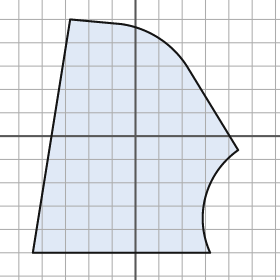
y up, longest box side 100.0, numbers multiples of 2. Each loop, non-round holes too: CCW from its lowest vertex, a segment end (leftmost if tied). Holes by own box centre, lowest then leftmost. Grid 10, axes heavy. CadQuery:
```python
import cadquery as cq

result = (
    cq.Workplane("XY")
    .moveTo(-44.0, -50.0)
    .lineTo(32.0, -50.0)
    .threePointArc((30.0, -26.0), (44.0, -6.0))
    .lineTo(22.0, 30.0)
    .threePointArc((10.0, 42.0), (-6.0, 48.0))
    .lineTo(-28.0, 50.0)
    .close()
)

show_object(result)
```